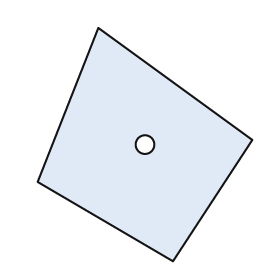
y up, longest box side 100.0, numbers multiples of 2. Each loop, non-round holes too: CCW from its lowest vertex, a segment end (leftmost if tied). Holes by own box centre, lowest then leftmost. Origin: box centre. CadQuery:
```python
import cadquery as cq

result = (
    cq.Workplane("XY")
    .moveTo(12.0, -50.0)
    .lineTo(46.0, 2.0)
    .lineTo(-20.0, 50.0)
    .lineTo(-46.0, -16.0)
    .close()
    .moveTo(0.0, 0.0)
    .circle(4.0)
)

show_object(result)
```